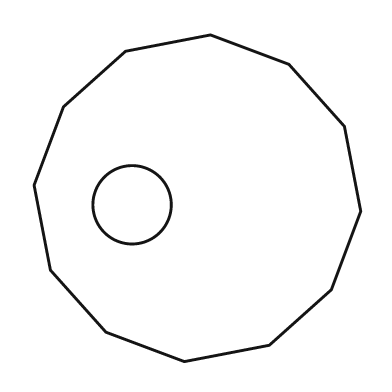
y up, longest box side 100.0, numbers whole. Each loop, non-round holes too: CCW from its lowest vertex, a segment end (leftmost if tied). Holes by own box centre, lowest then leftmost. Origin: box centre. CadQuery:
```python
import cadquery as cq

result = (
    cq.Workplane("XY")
    .moveTo(-4.0, -50.0)
    .lineTo(22.0, -45.0)
    .lineTo(41.0, -28.0)
    .lineTo(50.0, -4.0)
    .lineTo(45.0, 22.0)
    .lineTo(28.0, 41.0)
    .lineTo(4.0, 50.0)
    .lineTo(-22.0, 45.0)
    .lineTo(-41.0, 28.0)
    .lineTo(-50.0, 4.0)
    .lineTo(-45.0, -22.0)
    .lineTo(-28.0, -41.0)
    .close()
    .moveTo(-20.0, -2.0)
    .circle(12.0)
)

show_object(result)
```